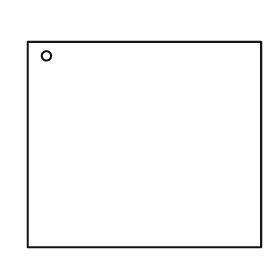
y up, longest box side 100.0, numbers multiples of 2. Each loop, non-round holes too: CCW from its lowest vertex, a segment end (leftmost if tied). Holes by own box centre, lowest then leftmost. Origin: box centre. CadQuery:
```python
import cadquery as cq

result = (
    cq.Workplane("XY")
    .moveTo(-50.0, -44.0)
    .lineTo(50.0, -44.0)
    .lineTo(50.0, 44.0)
    .lineTo(-50.0, 44.0)
    .close()
    .moveTo(-42.0, 38.0)
    .circle(2.0)
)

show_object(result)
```